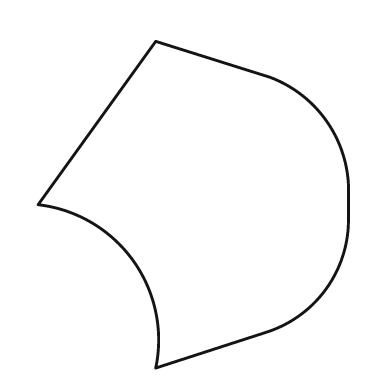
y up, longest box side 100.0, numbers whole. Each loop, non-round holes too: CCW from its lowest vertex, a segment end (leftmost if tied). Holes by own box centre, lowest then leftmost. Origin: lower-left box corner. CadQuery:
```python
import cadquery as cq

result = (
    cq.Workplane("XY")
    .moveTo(36.0, 0.0)
    .lineTo(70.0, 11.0)
    .threePointArc((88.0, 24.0), (95.0, 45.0))
    .lineTo(95.0, 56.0)
    .threePointArc((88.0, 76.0), (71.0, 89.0))
    .lineTo(36.0, 100.0)
    .lineTo(0.0, 50.0)
    .threePointArc((29.0, 33.0), (36.0, 0.0))
    .close()
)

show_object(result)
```